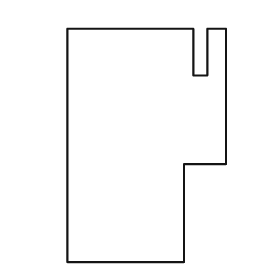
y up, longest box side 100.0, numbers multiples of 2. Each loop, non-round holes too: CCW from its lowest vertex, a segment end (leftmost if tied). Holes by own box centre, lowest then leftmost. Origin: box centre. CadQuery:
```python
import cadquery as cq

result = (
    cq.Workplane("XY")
    .moveTo(-34.0, -50.0)
    .lineTo(16.0, -50.0)
    .lineTo(16.0, -8.0)
    .lineTo(34.0, -8.0)
    .lineTo(34.0, 50.0)
    .lineTo(26.0, 50.0)
    .lineTo(26.0, 30.0)
    .lineTo(20.0, 30.0)
    .lineTo(20.0, 50.0)
    .lineTo(-34.0, 50.0)
    .close()
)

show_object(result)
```